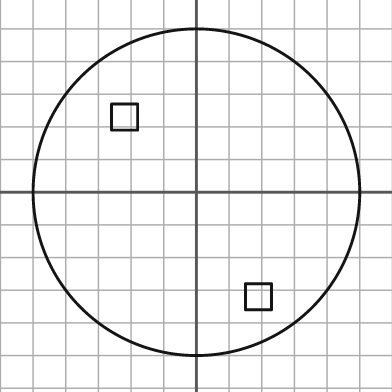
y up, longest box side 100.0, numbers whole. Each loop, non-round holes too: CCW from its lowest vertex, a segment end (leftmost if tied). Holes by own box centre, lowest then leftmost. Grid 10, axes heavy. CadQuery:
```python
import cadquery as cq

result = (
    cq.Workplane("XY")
    .moveTo(0.0, 0.0)
    .circle(50.0)
    .moveTo(15.0, -36.0)
    .lineTo(23.0, -36.0)
    .lineTo(23.0, -28.0)
    .lineTo(15.0, -28.0)
    .close()
    .moveTo(-26.0, 19.0)
    .lineTo(-18.0, 19.0)
    .lineTo(-18.0, 27.0)
    .lineTo(-26.0, 27.0)
    .close()
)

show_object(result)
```